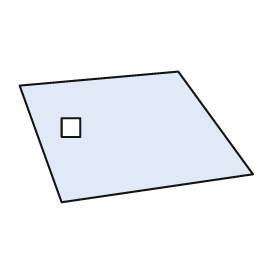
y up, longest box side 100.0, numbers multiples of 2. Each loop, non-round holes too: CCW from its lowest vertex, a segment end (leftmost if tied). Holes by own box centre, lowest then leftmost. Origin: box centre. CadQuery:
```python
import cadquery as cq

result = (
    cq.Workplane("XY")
    .moveTo(-32.0, -28.0)
    .lineTo(50.0, -16.0)
    .lineTo(18.0, 28.0)
    .lineTo(-50.0, 22.0)
    .close()
    .moveTo(-32.0, 0.0)
    .lineTo(-24.0, 0.0)
    .lineTo(-24.0, 8.0)
    .lineTo(-32.0, 8.0)
    .close()
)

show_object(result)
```